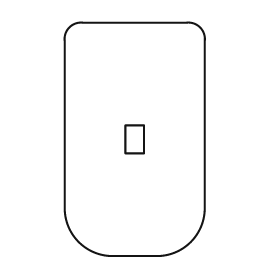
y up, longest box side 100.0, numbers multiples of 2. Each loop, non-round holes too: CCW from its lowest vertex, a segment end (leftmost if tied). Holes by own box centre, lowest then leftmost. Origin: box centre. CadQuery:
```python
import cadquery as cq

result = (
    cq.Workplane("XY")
    .moveTo(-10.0, -50.0)
    .lineTo(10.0, -50.0)
    .threePointArc((24.0, -44.0), (30.0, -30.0))
    .lineTo(30.0, 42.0)
    .threePointArc((28.0, 48.0), (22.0, 50.0))
    .lineTo(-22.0, 50.0)
    .threePointArc((-28.0, 48.0), (-30.0, 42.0))
    .lineTo(-30.0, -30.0)
    .threePointArc((-24.0, -44.0), (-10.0, -50.0))
    .close()
    .moveTo(-4.0, -6.0)
    .lineTo(4.0, -6.0)
    .lineTo(4.0, 6.0)
    .lineTo(-4.0, 6.0)
    .close()
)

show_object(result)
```